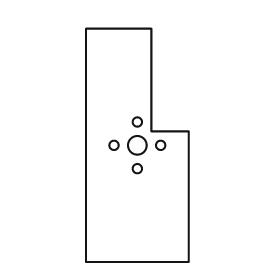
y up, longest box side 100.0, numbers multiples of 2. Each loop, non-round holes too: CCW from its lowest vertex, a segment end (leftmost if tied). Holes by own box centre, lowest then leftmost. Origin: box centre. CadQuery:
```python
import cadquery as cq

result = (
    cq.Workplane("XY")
    .moveTo(-22.0, -50.0)
    .lineTo(22.0, -50.0)
    .lineTo(22.0, 6.0)
    .lineTo(6.0, 6.0)
    .lineTo(6.0, 50.0)
    .lineTo(-22.0, 50.0)
    .close()
    .moveTo(0.0, -10.0)
    .circle(2.0)
    .moveTo(-10.0, 0.0)
    .circle(2.0)
    .moveTo(0.0, 0.0)
    .circle(4.0)
    .moveTo(10.0, 0.0)
    .circle(2.0)
    .moveTo(0.0, 10.0)
    .circle(2.0)
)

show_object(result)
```